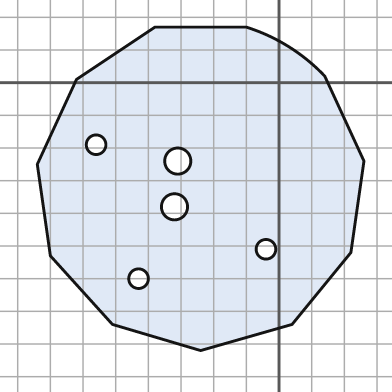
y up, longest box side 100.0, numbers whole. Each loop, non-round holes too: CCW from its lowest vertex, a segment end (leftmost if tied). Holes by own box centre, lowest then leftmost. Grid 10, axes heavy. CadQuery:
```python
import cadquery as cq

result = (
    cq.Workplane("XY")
    .moveTo(-24.0, -82.0)
    .lineTo(4.0, -74.0)
    .lineTo(22.0, -52.0)
    .lineTo(26.0, -24.0)
    .lineTo(14.0, 2.0)
    .threePointArc((3.0, 11.0), (-10.0, 17.0))
    .lineTo(-38.0, 17.0)
    .lineTo(-62.0, 1.0)
    .lineTo(-74.0, -25.0)
    .lineTo(-70.0, -53.0)
    .lineTo(-51.0, -74.0)
    .close()
    .moveTo(-43.0, -60.0)
    .circle(3.0)
    .moveTo(-4.0, -51.0)
    .circle(3.0)
    .moveTo(-32.0, -38.0)
    .circle(4.0)
    .moveTo(-31.0, -24.0)
    .circle(4.0)
    .moveTo(-56.0, -19.0)
    .circle(3.0)
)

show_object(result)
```